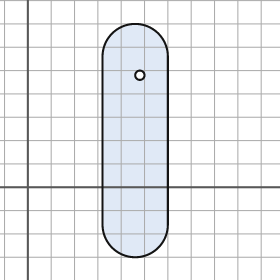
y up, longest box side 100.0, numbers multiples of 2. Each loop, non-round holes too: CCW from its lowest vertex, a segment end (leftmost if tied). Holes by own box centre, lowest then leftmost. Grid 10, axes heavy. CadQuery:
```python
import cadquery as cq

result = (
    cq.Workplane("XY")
    .moveTo(32.0, -16.0)
    .threePointArc((46.0, -30.0), (60.0, -16.0))
    .lineTo(60.0, 56.0)
    .threePointArc((46.0, 70.0), (32.0, 56.0))
    .close()
    .moveTo(48.0, 48.0)
    .circle(2.0)
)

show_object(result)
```